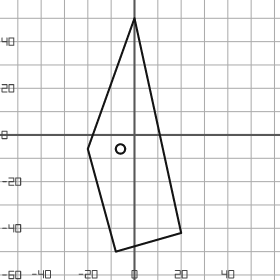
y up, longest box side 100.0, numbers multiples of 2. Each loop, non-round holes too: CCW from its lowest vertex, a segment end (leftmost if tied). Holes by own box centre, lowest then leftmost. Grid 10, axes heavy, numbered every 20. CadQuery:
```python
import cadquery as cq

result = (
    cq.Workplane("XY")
    .moveTo(-8.0, -50.0)
    .lineTo(20.0, -42.0)
    .lineTo(0.0, 50.0)
    .lineTo(-20.0, -6.0)
    .close()
    .moveTo(-6.0, -6.0)
    .circle(2.0)
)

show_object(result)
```